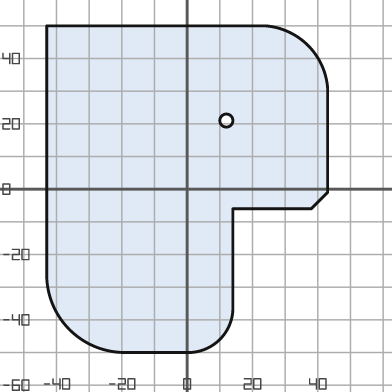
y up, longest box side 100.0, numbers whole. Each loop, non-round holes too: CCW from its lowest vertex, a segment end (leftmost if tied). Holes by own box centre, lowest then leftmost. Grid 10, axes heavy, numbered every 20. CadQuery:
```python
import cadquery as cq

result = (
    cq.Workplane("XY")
    .moveTo(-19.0, -50.0)
    .lineTo(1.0, -50.0)
    .threePointArc((10.0, -46.0), (14.0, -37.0))
    .lineTo(14.0, -6.0)
    .lineTo(38.0, -6.0)
    .lineTo(43.0, -1.0)
    .lineTo(43.0, 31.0)
    .threePointArc((37.0, 44.0), (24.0, 50.0))
    .lineTo(-43.0, 50.0)
    .lineTo(-43.0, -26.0)
    .threePointArc((-36.0, -43.0), (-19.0, -50.0))
    .close()
    .moveTo(12.0, 21.0)
    .circle(2.0)
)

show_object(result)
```